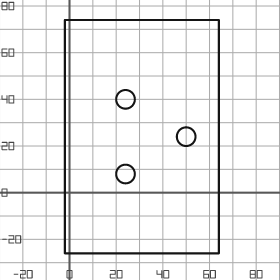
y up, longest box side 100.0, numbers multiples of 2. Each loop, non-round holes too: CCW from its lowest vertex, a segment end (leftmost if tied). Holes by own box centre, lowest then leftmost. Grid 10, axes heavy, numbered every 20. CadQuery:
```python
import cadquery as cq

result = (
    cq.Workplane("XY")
    .moveTo(-2.0, -26.0)
    .lineTo(64.0, -26.0)
    .lineTo(64.0, 74.0)
    .lineTo(-2.0, 74.0)
    .close()
    .moveTo(24.0, 8.0)
    .circle(4.0)
    .moveTo(50.0, 24.0)
    .circle(4.0)
    .moveTo(24.0, 40.0)
    .circle(4.0)
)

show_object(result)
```